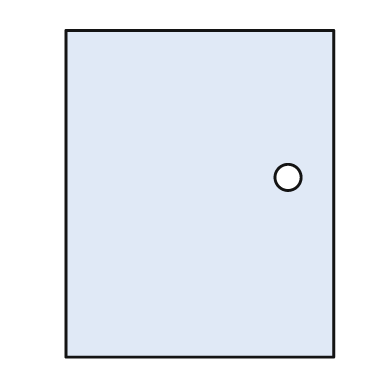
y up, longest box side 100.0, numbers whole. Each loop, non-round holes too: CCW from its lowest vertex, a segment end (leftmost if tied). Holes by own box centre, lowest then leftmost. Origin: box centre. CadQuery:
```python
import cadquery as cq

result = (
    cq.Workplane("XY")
    .moveTo(-41.0, -50.0)
    .lineTo(41.0, -50.0)
    .lineTo(41.0, 50.0)
    .lineTo(-41.0, 50.0)
    .close()
    .moveTo(27.0, 5.0)
    .circle(4.0)
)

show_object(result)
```